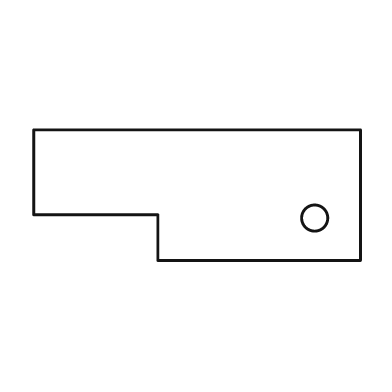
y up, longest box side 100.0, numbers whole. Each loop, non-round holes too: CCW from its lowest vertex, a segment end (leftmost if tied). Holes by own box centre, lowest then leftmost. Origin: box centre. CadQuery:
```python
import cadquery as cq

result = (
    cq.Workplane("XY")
    .moveTo(-12.0, -20.0)
    .lineTo(50.0, -20.0)
    .lineTo(50.0, 20.0)
    .lineTo(-50.0, 20.0)
    .lineTo(-50.0, -6.0)
    .lineTo(-12.0, -6.0)
    .close()
    .moveTo(36.0, -7.0)
    .circle(4.0)
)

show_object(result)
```